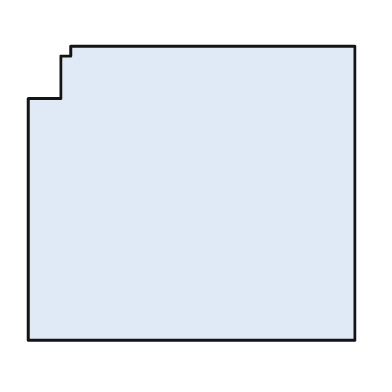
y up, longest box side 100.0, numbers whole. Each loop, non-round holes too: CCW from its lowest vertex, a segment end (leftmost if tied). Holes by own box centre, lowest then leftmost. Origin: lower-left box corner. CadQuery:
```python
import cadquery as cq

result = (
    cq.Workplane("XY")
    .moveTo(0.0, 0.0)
    .lineTo(100.0, 0.0)
    .lineTo(100.0, 90.0)
    .lineTo(13.0, 90.0)
    .lineTo(13.0, 87.0)
    .lineTo(10.0, 87.0)
    .lineTo(10.0, 74.0)
    .lineTo(0.0, 74.0)
    .close()
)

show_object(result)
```